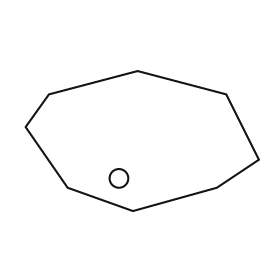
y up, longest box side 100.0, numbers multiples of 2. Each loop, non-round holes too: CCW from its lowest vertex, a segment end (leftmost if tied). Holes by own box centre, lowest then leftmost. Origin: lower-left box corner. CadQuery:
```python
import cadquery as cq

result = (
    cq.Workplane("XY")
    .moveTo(46.0, 0.0)
    .lineTo(82.0, 10.0)
    .lineTo(100.0, 22.0)
    .lineTo(86.0, 50.0)
    .lineTo(48.0, 60.0)
    .lineTo(10.0, 50.0)
    .lineTo(0.0, 36.0)
    .lineTo(18.0, 10.0)
    .close()
    .moveTo(40.0, 14.0)
    .circle(4.0)
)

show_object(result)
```